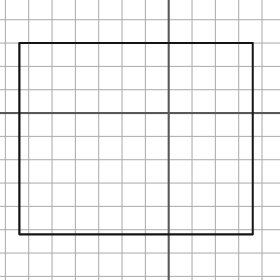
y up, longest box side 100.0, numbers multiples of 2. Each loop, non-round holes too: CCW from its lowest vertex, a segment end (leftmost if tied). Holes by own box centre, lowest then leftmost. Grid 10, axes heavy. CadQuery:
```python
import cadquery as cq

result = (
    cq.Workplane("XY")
    .moveTo(-64.0, -52.0)
    .lineTo(36.0, -52.0)
    .lineTo(36.0, 30.0)
    .lineTo(-64.0, 30.0)
    .close()
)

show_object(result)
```